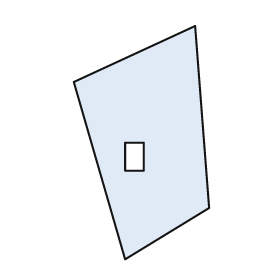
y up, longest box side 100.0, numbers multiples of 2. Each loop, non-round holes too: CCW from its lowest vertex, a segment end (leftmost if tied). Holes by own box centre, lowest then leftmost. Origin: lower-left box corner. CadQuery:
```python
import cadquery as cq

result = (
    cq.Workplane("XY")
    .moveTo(22.0, 0.0)
    .lineTo(58.0, 22.0)
    .lineTo(52.0, 100.0)
    .lineTo(0.0, 76.0)
    .close()
    .moveTo(22.0, 38.0)
    .lineTo(30.0, 38.0)
    .lineTo(30.0, 50.0)
    .lineTo(22.0, 50.0)
    .close()
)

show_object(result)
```